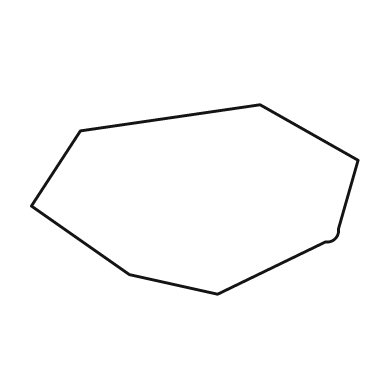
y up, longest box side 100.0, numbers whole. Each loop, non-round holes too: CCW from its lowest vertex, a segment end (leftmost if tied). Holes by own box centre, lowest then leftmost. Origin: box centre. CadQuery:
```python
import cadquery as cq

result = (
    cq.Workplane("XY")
    .moveTo(7.0, -29.0)
    .lineTo(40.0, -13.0)
    .threePointArc((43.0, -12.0), (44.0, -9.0))
    .lineTo(50.0, 12.0)
    .lineTo(20.0, 29.0)
    .lineTo(-35.0, 21.0)
    .lineTo(-50.0, -2.0)
    .lineTo(-20.0, -23.0)
    .close()
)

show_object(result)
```